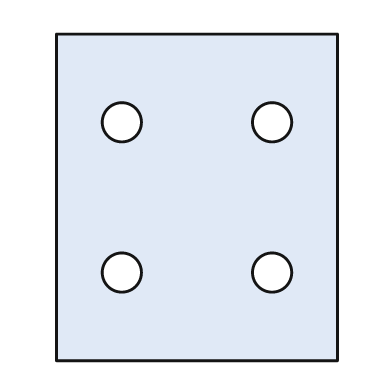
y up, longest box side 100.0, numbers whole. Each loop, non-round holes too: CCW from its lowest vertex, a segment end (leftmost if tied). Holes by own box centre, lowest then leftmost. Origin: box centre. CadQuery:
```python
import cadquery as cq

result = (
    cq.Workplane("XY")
    .moveTo(-43.0, -50.0)
    .lineTo(43.0, -50.0)
    .lineTo(43.0, 50.0)
    .lineTo(-43.0, 50.0)
    .close()
    .moveTo(-23.0, -23.0)
    .circle(6.0)
    .moveTo(23.0, -23.0)
    .circle(6.0)
    .moveTo(-23.0, 23.0)
    .circle(6.0)
    .moveTo(23.0, 23.0)
    .circle(6.0)
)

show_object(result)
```